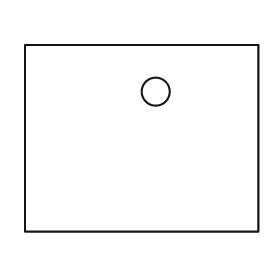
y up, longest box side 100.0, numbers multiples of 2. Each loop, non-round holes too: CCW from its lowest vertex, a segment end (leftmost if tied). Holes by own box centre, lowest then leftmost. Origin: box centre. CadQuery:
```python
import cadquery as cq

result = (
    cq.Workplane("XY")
    .moveTo(-50.0, -40.0)
    .lineTo(50.0, -40.0)
    .lineTo(50.0, 40.0)
    .lineTo(-50.0, 40.0)
    .close()
    .moveTo(6.0, 20.0)
    .circle(6.0)
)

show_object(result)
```